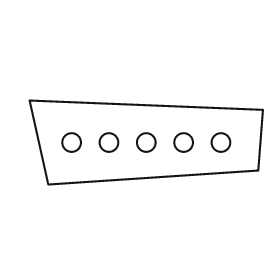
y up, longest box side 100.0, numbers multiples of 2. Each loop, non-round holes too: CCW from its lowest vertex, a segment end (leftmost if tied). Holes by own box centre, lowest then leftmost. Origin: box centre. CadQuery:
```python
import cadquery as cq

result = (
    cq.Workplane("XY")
    .moveTo(-42.0, -18.0)
    .lineTo(48.0, -12.0)
    .lineTo(50.0, 14.0)
    .lineTo(-50.0, 18.0)
    .close()
    .moveTo(-32.0, 0.0)
    .circle(4.0)
    .moveTo(-16.0, 0.0)
    .circle(4.0)
    .moveTo(0.0, 0.0)
    .circle(4.0)
    .moveTo(16.0, 0.0)
    .circle(4.0)
    .moveTo(32.0, 0.0)
    .circle(4.0)
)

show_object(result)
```